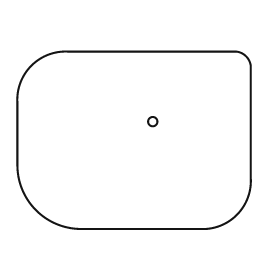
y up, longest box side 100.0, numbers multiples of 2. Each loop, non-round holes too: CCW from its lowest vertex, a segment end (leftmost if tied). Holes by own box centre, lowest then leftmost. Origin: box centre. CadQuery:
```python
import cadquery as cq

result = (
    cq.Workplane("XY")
    .moveTo(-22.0, -38.0)
    .lineTo(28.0, -38.0)
    .threePointArc((44.0, -32.0), (50.0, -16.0))
    .lineTo(50.0, 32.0)
    .threePointArc((48.0, 36.0), (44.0, 38.0))
    .lineTo(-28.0, 38.0)
    .threePointArc((-44.0, 32.0), (-50.0, 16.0))
    .lineTo(-50.0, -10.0)
    .threePointArc((-42.0, -30.0), (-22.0, -38.0))
    .close()
    .moveTo(8.0, 8.0)
    .circle(2.0)
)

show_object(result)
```